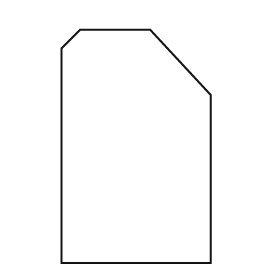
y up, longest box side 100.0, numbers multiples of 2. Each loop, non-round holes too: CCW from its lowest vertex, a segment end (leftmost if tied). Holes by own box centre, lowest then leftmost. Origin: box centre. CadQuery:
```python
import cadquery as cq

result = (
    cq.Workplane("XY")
    .moveTo(-32.0, -50.0)
    .lineTo(32.0, -50.0)
    .lineTo(32.0, 22.0)
    .lineTo(6.0, 50.0)
    .lineTo(-24.0, 50.0)
    .lineTo(-32.0, 42.0)
    .close()
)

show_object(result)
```